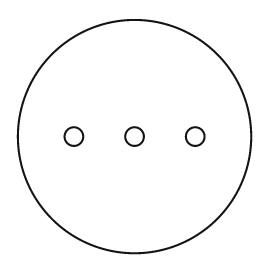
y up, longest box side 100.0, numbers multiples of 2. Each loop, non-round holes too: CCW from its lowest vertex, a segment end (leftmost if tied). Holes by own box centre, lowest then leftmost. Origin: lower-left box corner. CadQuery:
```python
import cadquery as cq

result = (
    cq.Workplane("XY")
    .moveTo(50.0, 50.0)
    .circle(50.0)
    .moveTo(24.0, 50.0)
    .circle(4.0)
    .moveTo(50.0, 50.0)
    .circle(4.0)
    .moveTo(76.0, 50.0)
    .circle(4.0)
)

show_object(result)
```